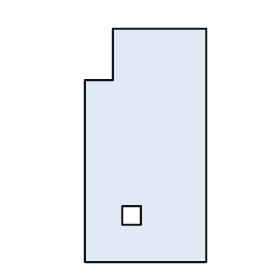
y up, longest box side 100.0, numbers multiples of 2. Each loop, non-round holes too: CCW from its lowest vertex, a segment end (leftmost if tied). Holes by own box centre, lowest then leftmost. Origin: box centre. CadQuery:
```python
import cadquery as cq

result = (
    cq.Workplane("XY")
    .moveTo(-26.0, -50.0)
    .lineTo(26.0, -50.0)
    .lineTo(26.0, 50.0)
    .lineTo(-14.0, 50.0)
    .lineTo(-14.0, 28.0)
    .lineTo(-26.0, 28.0)
    .close()
    .moveTo(-10.0, -34.0)
    .lineTo(-2.0, -34.0)
    .lineTo(-2.0, -26.0)
    .lineTo(-10.0, -26.0)
    .close()
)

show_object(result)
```